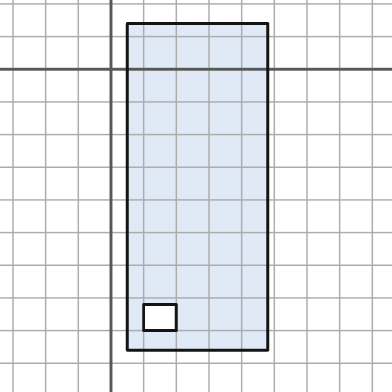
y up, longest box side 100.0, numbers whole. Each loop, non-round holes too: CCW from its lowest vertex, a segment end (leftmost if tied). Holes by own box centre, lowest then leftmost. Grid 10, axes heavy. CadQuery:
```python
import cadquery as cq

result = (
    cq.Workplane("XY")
    .moveTo(5.0, -86.0)
    .lineTo(48.0, -86.0)
    .lineTo(48.0, 14.0)
    .lineTo(5.0, 14.0)
    .close()
    .moveTo(10.0, -80.0)
    .lineTo(20.0, -80.0)
    .lineTo(20.0, -72.0)
    .lineTo(10.0, -72.0)
    .close()
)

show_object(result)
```